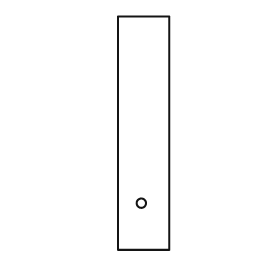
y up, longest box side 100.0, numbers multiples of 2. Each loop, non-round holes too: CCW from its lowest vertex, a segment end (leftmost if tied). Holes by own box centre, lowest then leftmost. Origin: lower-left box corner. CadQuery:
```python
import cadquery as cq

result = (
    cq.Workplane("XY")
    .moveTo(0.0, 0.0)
    .lineTo(22.0, 0.0)
    .lineTo(22.0, 100.0)
    .lineTo(0.0, 100.0)
    .close()
    .moveTo(10.0, 20.0)
    .circle(2.0)
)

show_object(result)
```